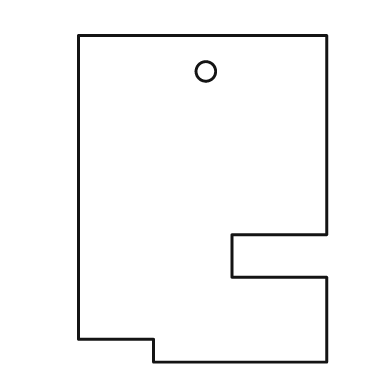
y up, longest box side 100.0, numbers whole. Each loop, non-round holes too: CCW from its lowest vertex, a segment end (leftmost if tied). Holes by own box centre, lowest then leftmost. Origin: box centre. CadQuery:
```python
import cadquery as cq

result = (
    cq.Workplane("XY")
    .moveTo(-15.0, -50.0)
    .lineTo(38.0, -50.0)
    .lineTo(38.0, -24.0)
    .lineTo(9.0, -24.0)
    .lineTo(9.0, -11.0)
    .lineTo(38.0, -11.0)
    .lineTo(38.0, 50.0)
    .lineTo(-38.0, 50.0)
    .lineTo(-38.0, -43.0)
    .lineTo(-15.0, -43.0)
    .close()
    .moveTo(1.0, 39.0)
    .circle(3.0)
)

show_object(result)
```